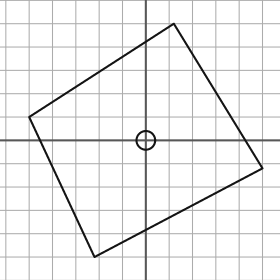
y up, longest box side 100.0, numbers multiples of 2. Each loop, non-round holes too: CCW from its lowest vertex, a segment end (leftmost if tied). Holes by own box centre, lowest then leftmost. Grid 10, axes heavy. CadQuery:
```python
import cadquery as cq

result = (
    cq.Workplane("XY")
    .moveTo(-22.0, -50.0)
    .lineTo(50.0, -12.0)
    .lineTo(12.0, 50.0)
    .lineTo(-50.0, 10.0)
    .close()
    .moveTo(0.0, 0.0)
    .circle(4.0)
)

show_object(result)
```